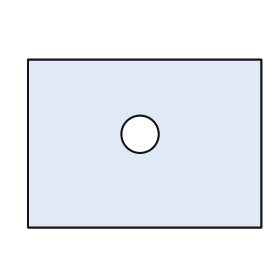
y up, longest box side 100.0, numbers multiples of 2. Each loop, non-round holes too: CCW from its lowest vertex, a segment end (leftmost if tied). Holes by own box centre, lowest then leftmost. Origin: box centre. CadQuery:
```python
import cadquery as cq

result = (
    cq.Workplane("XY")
    .moveTo(-50.0, -36.0)
    .lineTo(50.0, -36.0)
    .lineTo(50.0, 36.0)
    .lineTo(-50.0, 36.0)
    .close()
    .moveTo(-2.0, 4.0)
    .circle(8.0)
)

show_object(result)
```